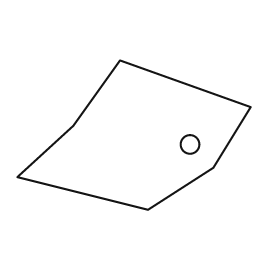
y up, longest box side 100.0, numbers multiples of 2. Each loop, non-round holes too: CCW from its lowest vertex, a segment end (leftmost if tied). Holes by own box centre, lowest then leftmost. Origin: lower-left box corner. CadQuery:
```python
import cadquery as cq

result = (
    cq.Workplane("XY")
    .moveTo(56.0, 0.0)
    .lineTo(84.0, 18.0)
    .lineTo(100.0, 44.0)
    .lineTo(44.0, 64.0)
    .lineTo(24.0, 36.0)
    .lineTo(0.0, 14.0)
    .close()
    .moveTo(74.0, 28.0)
    .circle(4.0)
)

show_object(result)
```